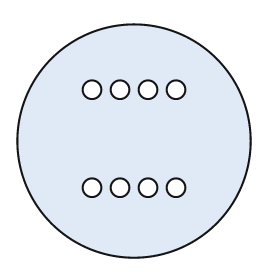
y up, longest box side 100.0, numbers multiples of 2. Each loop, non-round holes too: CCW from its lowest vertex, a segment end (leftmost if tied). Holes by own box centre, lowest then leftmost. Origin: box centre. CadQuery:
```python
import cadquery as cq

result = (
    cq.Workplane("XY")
    .moveTo(0.0, 0.0)
    .circle(50.0)
    .moveTo(-18.0, -20.0)
    .circle(4.0)
    .moveTo(-6.0, -20.0)
    .circle(4.0)
    .moveTo(6.0, -20.0)
    .circle(4.0)
    .moveTo(18.0, -20.0)
    .circle(4.0)
    .moveTo(-18.0, 22.0)
    .circle(4.0)
    .moveTo(-6.0, 22.0)
    .circle(4.0)
    .moveTo(6.0, 22.0)
    .circle(4.0)
    .moveTo(18.0, 22.0)
    .circle(4.0)
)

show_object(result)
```